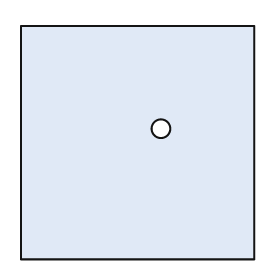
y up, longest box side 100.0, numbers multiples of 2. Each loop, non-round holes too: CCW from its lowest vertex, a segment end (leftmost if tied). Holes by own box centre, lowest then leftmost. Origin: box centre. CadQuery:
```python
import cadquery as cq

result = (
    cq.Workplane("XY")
    .moveTo(-50.0, -50.0)
    .lineTo(50.0, -50.0)
    .lineTo(50.0, 50.0)
    .lineTo(-50.0, 50.0)
    .close()
    .moveTo(10.0, 6.0)
    .circle(4.0)
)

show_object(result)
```